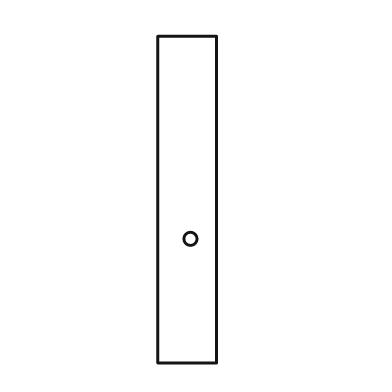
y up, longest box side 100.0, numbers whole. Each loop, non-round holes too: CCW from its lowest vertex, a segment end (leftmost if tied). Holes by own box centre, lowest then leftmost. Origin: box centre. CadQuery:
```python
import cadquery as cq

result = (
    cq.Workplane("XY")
    .moveTo(-9.0, -50.0)
    .lineTo(9.0, -50.0)
    .lineTo(9.0, 50.0)
    .lineTo(-9.0, 50.0)
    .close()
    .moveTo(1.0, -12.0)
    .circle(2.0)
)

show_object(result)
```